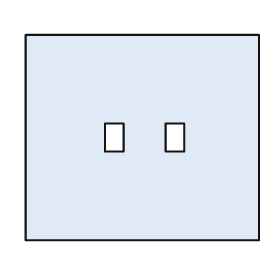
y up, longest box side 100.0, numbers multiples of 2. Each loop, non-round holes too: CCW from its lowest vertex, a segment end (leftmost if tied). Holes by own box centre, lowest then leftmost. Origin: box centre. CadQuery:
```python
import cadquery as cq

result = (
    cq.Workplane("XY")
    .moveTo(-50.0, -44.0)
    .lineTo(50.0, -44.0)
    .lineTo(50.0, 44.0)
    .lineTo(-50.0, 44.0)
    .close()
    .moveTo(-16.0, -6.0)
    .lineTo(-8.0, -6.0)
    .lineTo(-8.0, 6.0)
    .lineTo(-16.0, 6.0)
    .close()
    .moveTo(10.0, -6.0)
    .lineTo(18.0, -6.0)
    .lineTo(18.0, 6.0)
    .lineTo(10.0, 6.0)
    .close()
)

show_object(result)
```